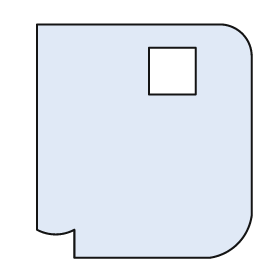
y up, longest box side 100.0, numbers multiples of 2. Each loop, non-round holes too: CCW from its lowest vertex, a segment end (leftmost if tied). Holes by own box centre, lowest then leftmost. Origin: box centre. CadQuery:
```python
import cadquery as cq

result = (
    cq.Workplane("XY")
    .moveTo(-30.0, -50.0)
    .lineTo(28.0, -50.0)
    .threePointArc((40.0, -44.0), (46.0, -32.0))
    .lineTo(46.0, 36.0)
    .threePointArc((42.0, 46.0), (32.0, 50.0))
    .lineTo(-46.0, 50.0)
    .lineTo(-46.0, -38.0)
    .threePointArc((-38.0, -40.0), (-30.0, -38.0))
    .close()
    .moveTo(2.0, 20.0)
    .lineTo(22.0, 20.0)
    .lineTo(22.0, 40.0)
    .lineTo(2.0, 40.0)
    .close()
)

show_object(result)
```